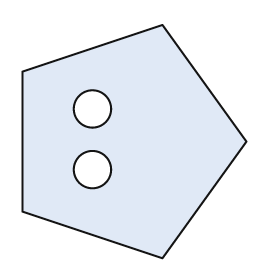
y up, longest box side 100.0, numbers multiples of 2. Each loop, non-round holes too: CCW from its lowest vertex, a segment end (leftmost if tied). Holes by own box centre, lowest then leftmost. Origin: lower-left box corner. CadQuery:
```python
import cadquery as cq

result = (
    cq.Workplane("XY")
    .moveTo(60.0, 0.0)
    .lineTo(96.0, 50.0)
    .lineTo(60.0, 100.0)
    .lineTo(0.0, 80.0)
    .lineTo(0.0, 20.0)
    .close()
    .moveTo(30.0, 38.0)
    .circle(8.0)
    .moveTo(30.0, 64.0)
    .circle(8.0)
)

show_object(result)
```